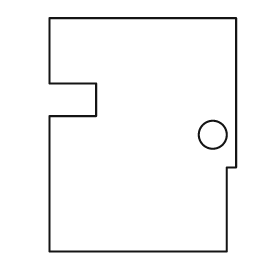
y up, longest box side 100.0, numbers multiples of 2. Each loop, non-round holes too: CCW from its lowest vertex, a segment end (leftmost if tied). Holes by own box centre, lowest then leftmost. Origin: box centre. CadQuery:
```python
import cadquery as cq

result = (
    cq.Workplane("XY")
    .moveTo(-40.0, -50.0)
    .lineTo(36.0, -50.0)
    .lineTo(36.0, -14.0)
    .lineTo(40.0, -14.0)
    .lineTo(40.0, 50.0)
    .lineTo(-40.0, 50.0)
    .lineTo(-40.0, 22.0)
    .lineTo(-20.0, 22.0)
    .lineTo(-20.0, 8.0)
    .lineTo(-40.0, 8.0)
    .close()
    .moveTo(30.0, 0.0)
    .circle(6.0)
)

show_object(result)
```